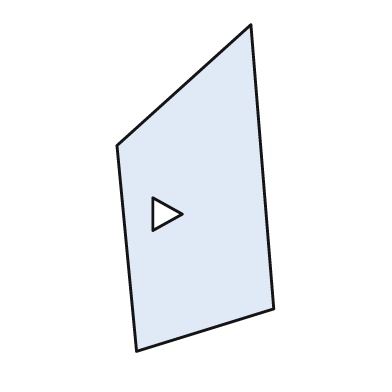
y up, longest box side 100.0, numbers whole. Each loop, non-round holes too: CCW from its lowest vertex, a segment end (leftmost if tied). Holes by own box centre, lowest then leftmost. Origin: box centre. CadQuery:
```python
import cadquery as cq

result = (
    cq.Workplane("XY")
    .moveTo(-18.0, -50.0)
    .lineTo(24.0, -37.0)
    .lineTo(17.0, 50.0)
    .lineTo(-24.0, 13.0)
    .close()
    .moveTo(-13.0, -13.0)
    .lineTo(-4.0, -8.0)
    .lineTo(-13.0, -3.0)
    .close()
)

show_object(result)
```